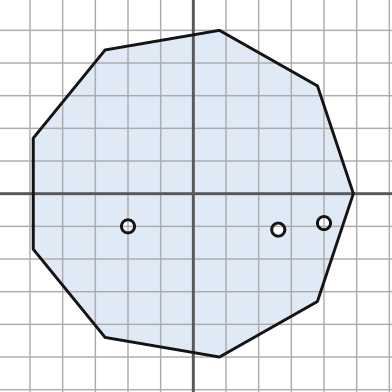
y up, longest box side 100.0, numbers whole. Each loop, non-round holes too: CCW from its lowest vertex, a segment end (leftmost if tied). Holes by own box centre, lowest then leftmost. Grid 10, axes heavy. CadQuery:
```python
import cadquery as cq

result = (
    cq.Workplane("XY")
    .moveTo(8.0, -50.0)
    .lineTo(38.0, -33.0)
    .lineTo(49.0, 0.0)
    .lineTo(38.0, 33.0)
    .lineTo(8.0, 50.0)
    .lineTo(-27.0, 44.0)
    .lineTo(-49.0, 17.0)
    .lineTo(-49.0, -17.0)
    .lineTo(-27.0, -44.0)
    .close()
    .moveTo(26.0, -11.0)
    .circle(2.0)
    .moveTo(-20.0, -10.0)
    .circle(2.0)
    .moveTo(40.0, -9.0)
    .circle(2.0)
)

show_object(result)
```